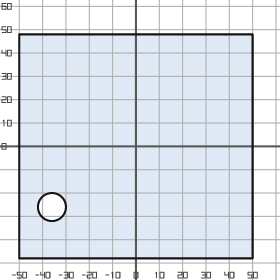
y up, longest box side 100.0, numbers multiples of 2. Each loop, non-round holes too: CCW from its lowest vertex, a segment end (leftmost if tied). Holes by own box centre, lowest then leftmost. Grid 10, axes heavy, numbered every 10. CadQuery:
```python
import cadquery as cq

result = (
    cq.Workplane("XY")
    .moveTo(-50.0, -48.0)
    .lineTo(50.0, -48.0)
    .lineTo(50.0, 48.0)
    .lineTo(-50.0, 48.0)
    .close()
    .moveTo(-36.0, -26.0)
    .circle(6.0)
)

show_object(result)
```